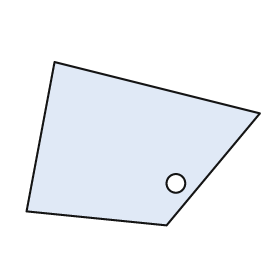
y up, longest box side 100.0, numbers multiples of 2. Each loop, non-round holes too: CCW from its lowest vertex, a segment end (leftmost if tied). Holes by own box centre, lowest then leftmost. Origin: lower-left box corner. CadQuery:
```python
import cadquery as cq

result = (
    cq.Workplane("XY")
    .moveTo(60.0, 0.0)
    .lineTo(100.0, 48.0)
    .lineTo(12.0, 70.0)
    .lineTo(0.0, 6.0)
    .close()
    .moveTo(64.0, 18.0)
    .circle(4.0)
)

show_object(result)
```